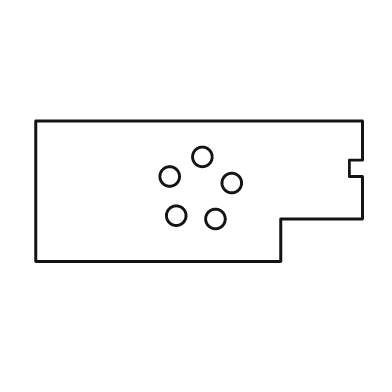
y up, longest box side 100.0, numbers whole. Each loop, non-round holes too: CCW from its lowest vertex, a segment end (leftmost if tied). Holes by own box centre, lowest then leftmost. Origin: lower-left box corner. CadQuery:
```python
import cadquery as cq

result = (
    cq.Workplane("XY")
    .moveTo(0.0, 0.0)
    .lineTo(75.0, 0.0)
    .lineTo(75.0, 13.0)
    .lineTo(100.0, 13.0)
    .lineTo(100.0, 26.0)
    .lineTo(96.0, 26.0)
    .lineTo(96.0, 31.0)
    .lineTo(100.0, 31.0)
    .lineTo(100.0, 43.0)
    .lineTo(0.0, 43.0)
    .close()
    .moveTo(55.0, 13.0)
    .circle(3.0)
    .moveTo(43.0, 14.0)
    .circle(3.0)
    .moveTo(60.0, 24.0)
    .circle(3.0)
    .moveTo(41.0, 26.0)
    .circle(3.0)
    .moveTo(51.0, 32.0)
    .circle(3.0)
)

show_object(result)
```